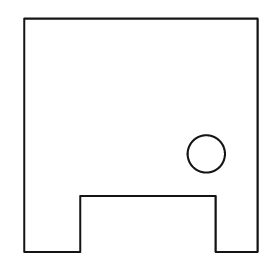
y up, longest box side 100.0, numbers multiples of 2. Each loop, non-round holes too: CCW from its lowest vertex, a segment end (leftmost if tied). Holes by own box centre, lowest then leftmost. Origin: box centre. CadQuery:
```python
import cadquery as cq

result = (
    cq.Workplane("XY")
    .moveTo(-50.0, -50.0)
    .lineTo(-26.0, -50.0)
    .lineTo(-26.0, -26.0)
    .lineTo(32.0, -26.0)
    .lineTo(32.0, -50.0)
    .lineTo(50.0, -50.0)
    .lineTo(50.0, 50.0)
    .lineTo(-50.0, 50.0)
    .close()
    .moveTo(28.0, -8.0)
    .circle(8.0)
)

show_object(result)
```